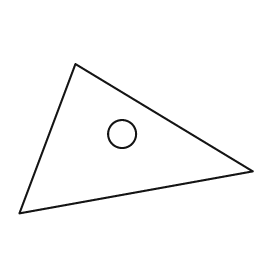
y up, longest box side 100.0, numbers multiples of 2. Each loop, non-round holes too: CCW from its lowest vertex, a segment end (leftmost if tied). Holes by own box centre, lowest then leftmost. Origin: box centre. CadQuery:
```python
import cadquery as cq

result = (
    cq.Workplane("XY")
    .moveTo(-50.0, -32.0)
    .lineTo(50.0, -14.0)
    .lineTo(-26.0, 32.0)
    .close()
    .moveTo(-6.0, 2.0)
    .circle(6.0)
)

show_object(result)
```